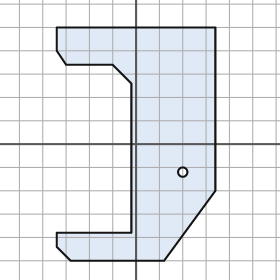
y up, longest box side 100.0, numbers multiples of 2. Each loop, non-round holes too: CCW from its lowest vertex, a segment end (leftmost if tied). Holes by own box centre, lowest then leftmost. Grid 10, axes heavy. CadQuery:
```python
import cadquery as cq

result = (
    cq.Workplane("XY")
    .moveTo(-28.0, -50.0)
    .lineTo(12.0, -50.0)
    .lineTo(34.0, -20.0)
    .lineTo(34.0, 50.0)
    .lineTo(-34.0, 50.0)
    .lineTo(-34.0, 40.0)
    .lineTo(-30.0, 34.0)
    .lineTo(-10.0, 34.0)
    .lineTo(-2.0, 26.0)
    .lineTo(-2.0, -38.0)
    .lineTo(-34.0, -38.0)
    .lineTo(-34.0, -44.0)
    .close()
    .moveTo(20.0, -12.0)
    .circle(2.0)
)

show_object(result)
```